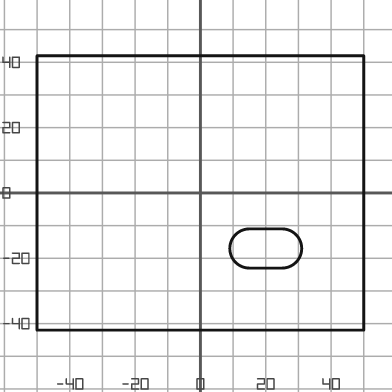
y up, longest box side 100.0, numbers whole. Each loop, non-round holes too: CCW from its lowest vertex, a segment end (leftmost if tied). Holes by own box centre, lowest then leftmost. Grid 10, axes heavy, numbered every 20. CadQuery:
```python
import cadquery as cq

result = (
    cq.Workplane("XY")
    .moveTo(-50.0, -42.0)
    .lineTo(50.0, -42.0)
    .lineTo(50.0, 42.0)
    .lineTo(-50.0, 42.0)
    .close()
    .moveTo(15.0, -23.0)
    .lineTo(25.0, -23.0)
    .threePointArc((31.0, -17.0), (25.0, -11.0))
    .lineTo(15.0, -11.0)
    .threePointArc((9.0, -17.0), (15.0, -23.0))
    .close()
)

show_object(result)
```